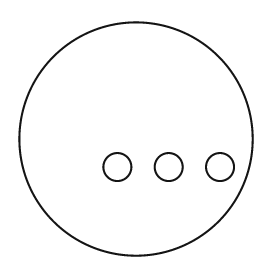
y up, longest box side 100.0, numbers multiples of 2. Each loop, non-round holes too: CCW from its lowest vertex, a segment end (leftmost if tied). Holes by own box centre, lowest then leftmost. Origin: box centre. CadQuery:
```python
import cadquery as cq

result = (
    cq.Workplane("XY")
    .moveTo(0.0, 0.0)
    .circle(50.0)
    .moveTo(-8.0, -12.0)
    .circle(6.0)
    .moveTo(14.0, -12.0)
    .circle(6.0)
    .moveTo(36.0, -12.0)
    .circle(6.0)
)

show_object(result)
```